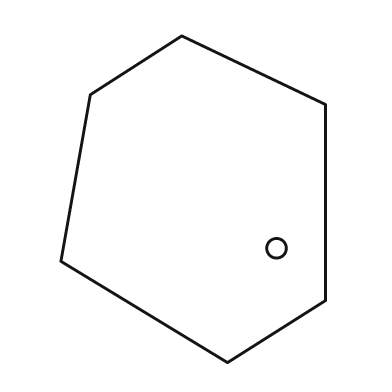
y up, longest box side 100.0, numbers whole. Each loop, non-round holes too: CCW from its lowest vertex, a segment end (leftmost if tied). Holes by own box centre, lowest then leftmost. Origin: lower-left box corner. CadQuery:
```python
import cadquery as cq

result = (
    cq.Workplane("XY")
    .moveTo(51.0, 0.0)
    .lineTo(81.0, 19.0)
    .lineTo(81.0, 79.0)
    .lineTo(37.0, 100.0)
    .lineTo(9.0, 82.0)
    .lineTo(0.0, 31.0)
    .close()
    .moveTo(66.0, 35.0)
    .circle(3.0)
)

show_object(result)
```